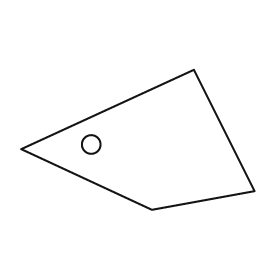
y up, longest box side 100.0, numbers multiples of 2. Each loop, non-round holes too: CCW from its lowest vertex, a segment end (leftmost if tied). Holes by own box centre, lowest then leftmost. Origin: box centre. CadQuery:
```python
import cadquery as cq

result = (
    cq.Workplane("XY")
    .moveTo(6.0, -30.0)
    .lineTo(50.0, -22.0)
    .lineTo(24.0, 30.0)
    .lineTo(-50.0, -4.0)
    .close()
    .moveTo(-20.0, -2.0)
    .circle(4.0)
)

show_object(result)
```